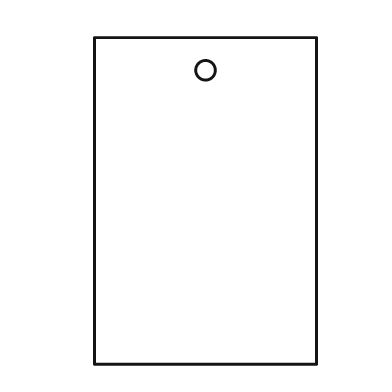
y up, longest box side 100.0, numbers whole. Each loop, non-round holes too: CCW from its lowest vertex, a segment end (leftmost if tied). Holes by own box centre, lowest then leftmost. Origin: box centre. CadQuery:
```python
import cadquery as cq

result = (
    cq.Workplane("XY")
    .moveTo(-34.0, -50.0)
    .lineTo(34.0, -50.0)
    .lineTo(34.0, 50.0)
    .lineTo(-34.0, 50.0)
    .close()
    .moveTo(0.0, 40.0)
    .circle(3.0)
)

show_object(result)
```